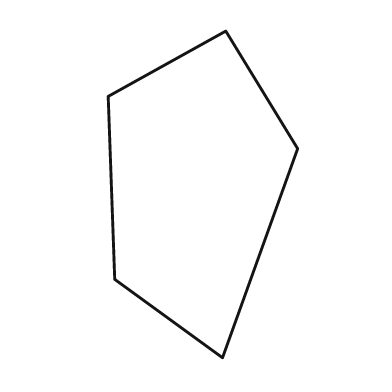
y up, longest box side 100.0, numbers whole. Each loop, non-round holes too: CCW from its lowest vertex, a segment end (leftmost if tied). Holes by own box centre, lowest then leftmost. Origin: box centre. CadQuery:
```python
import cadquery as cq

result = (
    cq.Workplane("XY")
    .moveTo(6.0, -50.0)
    .lineTo(29.0, 14.0)
    .lineTo(7.0, 50.0)
    .lineTo(-29.0, 30.0)
    .lineTo(-27.0, -26.0)
    .close()
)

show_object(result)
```